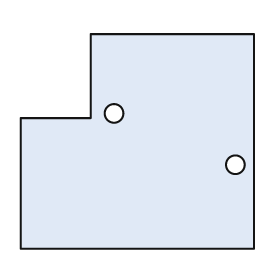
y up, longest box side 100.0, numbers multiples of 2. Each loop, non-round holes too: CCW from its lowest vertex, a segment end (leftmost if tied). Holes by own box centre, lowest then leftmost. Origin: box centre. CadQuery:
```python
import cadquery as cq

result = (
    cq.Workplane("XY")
    .moveTo(-50.0, -46.0)
    .lineTo(50.0, -46.0)
    .lineTo(50.0, 46.0)
    .lineTo(-20.0, 46.0)
    .lineTo(-20.0, 10.0)
    .lineTo(-50.0, 10.0)
    .close()
    .moveTo(42.0, -10.0)
    .circle(4.0)
    .moveTo(-10.0, 12.0)
    .circle(4.0)
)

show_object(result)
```